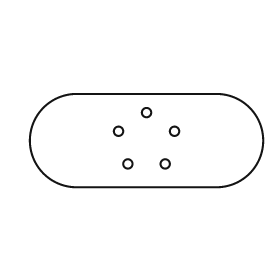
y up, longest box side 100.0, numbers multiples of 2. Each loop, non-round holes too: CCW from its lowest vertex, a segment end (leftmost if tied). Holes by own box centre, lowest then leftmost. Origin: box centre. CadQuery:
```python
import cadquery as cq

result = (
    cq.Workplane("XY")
    .moveTo(-30.0, -20.0)
    .lineTo(30.0, -20.0)
    .threePointArc((50.0, 0.0), (30.0, 20.0))
    .lineTo(-30.0, 20.0)
    .threePointArc((-50.0, 0.0), (-30.0, -20.0))
    .close()
    .moveTo(-8.0, -10.0)
    .circle(2.0)
    .moveTo(8.0, -10.0)
    .circle(2.0)
    .moveTo(-12.0, 4.0)
    .circle(2.0)
    .moveTo(12.0, 4.0)
    .circle(2.0)
    .moveTo(0.0, 12.0)
    .circle(2.0)
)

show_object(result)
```